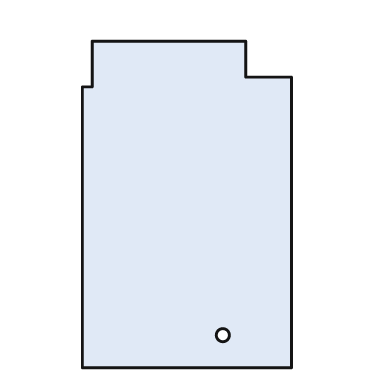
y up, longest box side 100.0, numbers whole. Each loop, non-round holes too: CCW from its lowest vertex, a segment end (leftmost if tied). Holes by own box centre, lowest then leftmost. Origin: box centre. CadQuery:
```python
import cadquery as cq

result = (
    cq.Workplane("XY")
    .moveTo(-32.0, -50.0)
    .lineTo(32.0, -50.0)
    .lineTo(32.0, 39.0)
    .lineTo(18.0, 39.0)
    .lineTo(18.0, 50.0)
    .lineTo(-29.0, 50.0)
    .lineTo(-29.0, 36.0)
    .lineTo(-32.0, 36.0)
    .close()
    .moveTo(11.0, -40.0)
    .circle(2.0)
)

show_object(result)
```